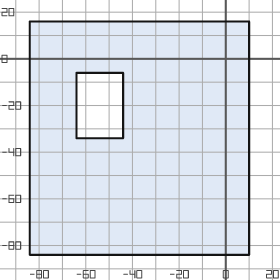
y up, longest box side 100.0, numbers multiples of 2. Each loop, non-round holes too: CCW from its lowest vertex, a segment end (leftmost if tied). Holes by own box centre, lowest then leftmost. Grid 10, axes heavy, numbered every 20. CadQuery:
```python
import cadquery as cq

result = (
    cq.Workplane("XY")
    .moveTo(-84.0, -84.0)
    .lineTo(10.0, -84.0)
    .lineTo(10.0, 16.0)
    .lineTo(-84.0, 16.0)
    .close()
    .moveTo(-64.0, -34.0)
    .lineTo(-44.0, -34.0)
    .lineTo(-44.0, -6.0)
    .lineTo(-64.0, -6.0)
    .close()
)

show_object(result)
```